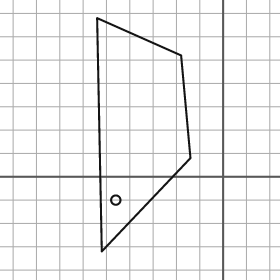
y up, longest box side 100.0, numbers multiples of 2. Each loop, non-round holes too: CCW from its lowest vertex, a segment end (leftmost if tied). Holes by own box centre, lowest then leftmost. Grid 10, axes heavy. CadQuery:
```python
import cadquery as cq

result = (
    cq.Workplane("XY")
    .moveTo(-52.0, -32.0)
    .lineTo(-14.0, 8.0)
    .lineTo(-18.0, 52.0)
    .lineTo(-54.0, 68.0)
    .close()
    .moveTo(-46.0, -10.0)
    .circle(2.0)
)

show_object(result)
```